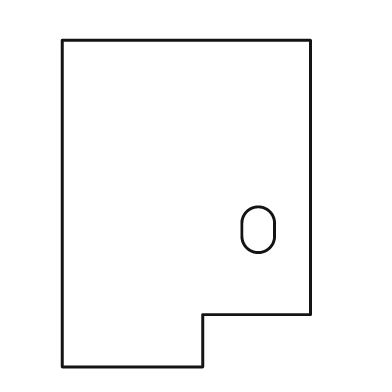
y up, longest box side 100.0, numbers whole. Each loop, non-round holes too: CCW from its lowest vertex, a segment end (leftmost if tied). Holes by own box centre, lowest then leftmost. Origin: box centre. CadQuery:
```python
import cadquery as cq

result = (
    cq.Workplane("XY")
    .moveTo(-38.0, -50.0)
    .lineTo(5.0, -50.0)
    .lineTo(5.0, -34.0)
    .lineTo(38.0, -34.0)
    .lineTo(38.0, 50.0)
    .lineTo(-38.0, 50.0)
    .close()
    .moveTo(17.0, -10.0)
    .threePointArc((22.0, -15.0), (27.0, -10.0))
    .lineTo(27.0, -6.0)
    .threePointArc((22.0, -1.0), (17.0, -6.0))
    .close()
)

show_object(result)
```